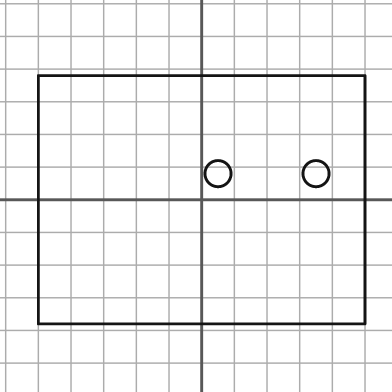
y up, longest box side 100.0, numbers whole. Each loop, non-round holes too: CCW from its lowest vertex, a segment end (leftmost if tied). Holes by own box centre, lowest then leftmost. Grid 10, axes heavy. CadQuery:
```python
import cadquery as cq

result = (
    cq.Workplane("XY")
    .moveTo(-50.0, -38.0)
    .lineTo(50.0, -38.0)
    .lineTo(50.0, 38.0)
    .lineTo(-50.0, 38.0)
    .close()
    .moveTo(5.0, 8.0)
    .circle(4.0)
    .moveTo(35.0, 8.0)
    .circle(4.0)
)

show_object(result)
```